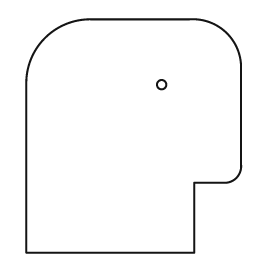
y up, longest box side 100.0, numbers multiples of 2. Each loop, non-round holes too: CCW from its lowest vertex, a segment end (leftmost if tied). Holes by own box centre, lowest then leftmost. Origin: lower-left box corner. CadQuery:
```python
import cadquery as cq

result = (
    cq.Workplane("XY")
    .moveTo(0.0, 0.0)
    .lineTo(72.0, 0.0)
    .lineTo(72.0, 30.0)
    .lineTo(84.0, 30.0)
    .threePointArc((90.0, 32.0), (92.0, 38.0))
    .lineTo(92.0, 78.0)
    .threePointArc((86.0, 94.0), (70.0, 100.0))
    .lineTo(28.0, 100.0)
    .threePointArc((8.0, 92.0), (0.0, 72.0))
    .close()
    .moveTo(58.0, 72.0)
    .circle(2.0)
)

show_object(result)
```